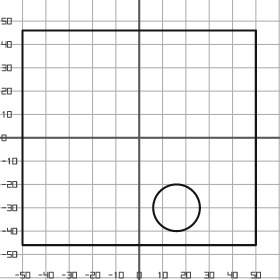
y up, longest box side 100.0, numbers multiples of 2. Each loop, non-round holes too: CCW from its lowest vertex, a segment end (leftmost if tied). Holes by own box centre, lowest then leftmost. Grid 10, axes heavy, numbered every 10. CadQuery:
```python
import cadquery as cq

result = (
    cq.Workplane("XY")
    .moveTo(-50.0, -46.0)
    .lineTo(50.0, -46.0)
    .lineTo(50.0, 46.0)
    .lineTo(-50.0, 46.0)
    .close()
    .moveTo(16.0, -30.0)
    .circle(10.0)
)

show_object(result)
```